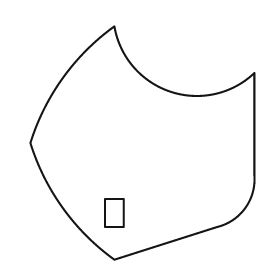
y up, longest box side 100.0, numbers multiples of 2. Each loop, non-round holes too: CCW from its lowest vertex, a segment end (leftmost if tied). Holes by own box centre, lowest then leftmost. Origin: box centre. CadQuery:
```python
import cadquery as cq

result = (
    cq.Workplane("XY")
    .moveTo(-12.0, -50.0)
    .lineTo(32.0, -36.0)
    .threePointArc((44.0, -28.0), (48.0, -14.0))
    .lineTo(48.0, 30.0)
    .threePointArc((12.0, 22.0), (-12.0, 50.0))
    .threePointArc((-34.0, 28.0), (-48.0, 0.0))
    .threePointArc((-34.0, -28.0), (-12.0, -50.0))
    .close()
    .moveTo(-16.0, -36.0)
    .lineTo(-8.0, -36.0)
    .lineTo(-8.0, -24.0)
    .lineTo(-16.0, -24.0)
    .close()
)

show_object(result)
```